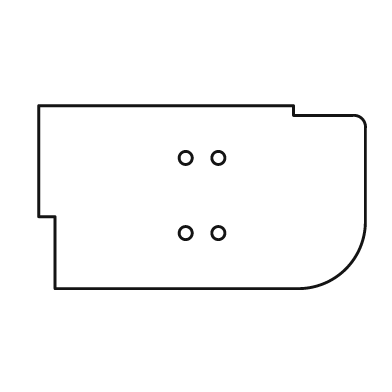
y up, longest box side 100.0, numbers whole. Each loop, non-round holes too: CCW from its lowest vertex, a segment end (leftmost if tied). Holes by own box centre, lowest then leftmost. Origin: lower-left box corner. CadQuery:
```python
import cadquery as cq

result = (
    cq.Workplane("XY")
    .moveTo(5.0, 0.0)
    .lineTo(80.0, 0.0)
    .threePointArc((94.0, 6.0), (100.0, 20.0))
    .lineTo(100.0, 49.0)
    .threePointArc((99.0, 52.0), (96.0, 53.0))
    .lineTo(78.0, 53.0)
    .lineTo(78.0, 56.0)
    .lineTo(0.0, 56.0)
    .lineTo(0.0, 22.0)
    .lineTo(5.0, 22.0)
    .close()
    .moveTo(45.0, 17.0)
    .circle(2.0)
    .moveTo(55.0, 17.0)
    .circle(2.0)
    .moveTo(45.0, 40.0)
    .circle(2.0)
    .moveTo(55.0, 40.0)
    .circle(2.0)
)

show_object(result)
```